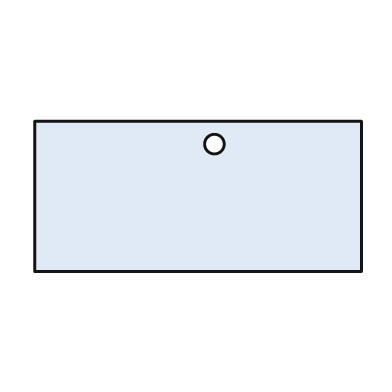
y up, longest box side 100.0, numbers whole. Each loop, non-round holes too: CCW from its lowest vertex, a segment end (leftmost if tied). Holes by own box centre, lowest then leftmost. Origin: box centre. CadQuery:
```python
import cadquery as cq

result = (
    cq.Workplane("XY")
    .moveTo(-50.0, -23.0)
    .lineTo(50.0, -23.0)
    .lineTo(50.0, 23.0)
    .lineTo(-50.0, 23.0)
    .close()
    .moveTo(5.0, 16.0)
    .circle(3.0)
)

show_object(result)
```